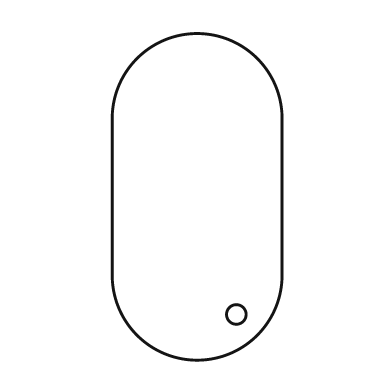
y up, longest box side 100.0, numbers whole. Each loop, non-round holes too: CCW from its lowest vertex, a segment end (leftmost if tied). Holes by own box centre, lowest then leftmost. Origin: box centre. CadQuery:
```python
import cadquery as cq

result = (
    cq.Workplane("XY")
    .moveTo(-26.0, -24.0)
    .threePointArc((0.0, -50.0), (26.0, -24.0))
    .lineTo(26.0, 24.0)
    .threePointArc((0.0, 50.0), (-26.0, 24.0))
    .close()
    .moveTo(12.0, -36.0)
    .circle(3.0)
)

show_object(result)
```